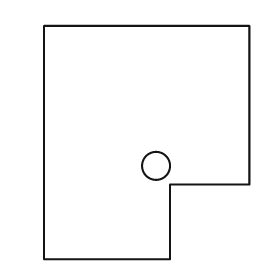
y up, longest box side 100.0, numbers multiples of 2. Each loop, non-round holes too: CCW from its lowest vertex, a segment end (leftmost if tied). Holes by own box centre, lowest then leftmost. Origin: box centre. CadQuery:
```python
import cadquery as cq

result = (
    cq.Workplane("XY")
    .moveTo(-44.0, -50.0)
    .lineTo(10.0, -50.0)
    .lineTo(10.0, -18.0)
    .lineTo(44.0, -18.0)
    .lineTo(44.0, 50.0)
    .lineTo(-44.0, 50.0)
    .close()
    .moveTo(4.0, -10.0)
    .circle(6.0)
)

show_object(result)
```